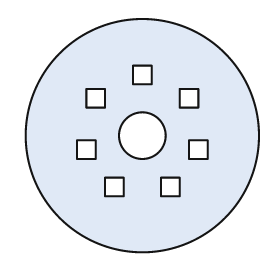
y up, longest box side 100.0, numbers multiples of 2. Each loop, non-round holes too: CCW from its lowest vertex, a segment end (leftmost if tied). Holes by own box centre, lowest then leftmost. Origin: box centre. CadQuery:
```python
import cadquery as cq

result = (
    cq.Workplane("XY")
    .moveTo(0.0, 0.0)
    .circle(50.0)
    .moveTo(-16.0, -26.0)
    .lineTo(-8.0, -26.0)
    .lineTo(-8.0, -18.0)
    .lineTo(-16.0, -18.0)
    .close()
    .moveTo(8.0, -26.0)
    .lineTo(16.0, -26.0)
    .lineTo(16.0, -18.0)
    .lineTo(8.0, -18.0)
    .close()
    .moveTo(-28.0, -10.0)
    .lineTo(-20.0, -10.0)
    .lineTo(-20.0, -2.0)
    .lineTo(-28.0, -2.0)
    .close()
    .moveTo(20.0, -10.0)
    .lineTo(28.0, -10.0)
    .lineTo(28.0, -2.0)
    .lineTo(20.0, -2.0)
    .close()
    .moveTo(0.0, 0.0)
    .circle(10.0)
    .moveTo(-24.0, 12.0)
    .lineTo(-16.0, 12.0)
    .lineTo(-16.0, 20.0)
    .lineTo(-24.0, 20.0)
    .close()
    .moveTo(16.0, 12.0)
    .lineTo(24.0, 12.0)
    .lineTo(24.0, 20.0)
    .lineTo(16.0, 20.0)
    .close()
    .moveTo(-4.0, 22.0)
    .lineTo(4.0, 22.0)
    .lineTo(4.0, 30.0)
    .lineTo(-4.0, 30.0)
    .close()
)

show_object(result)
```